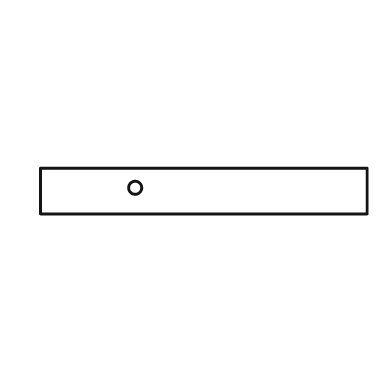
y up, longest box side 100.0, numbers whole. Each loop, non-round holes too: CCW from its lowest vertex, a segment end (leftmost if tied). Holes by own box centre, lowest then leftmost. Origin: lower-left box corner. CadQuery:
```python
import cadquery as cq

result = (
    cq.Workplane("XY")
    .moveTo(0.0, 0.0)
    .lineTo(100.0, 0.0)
    .lineTo(100.0, 14.0)
    .lineTo(0.0, 14.0)
    .close()
    .moveTo(29.0, 8.0)
    .circle(2.0)
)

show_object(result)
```